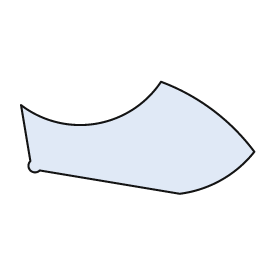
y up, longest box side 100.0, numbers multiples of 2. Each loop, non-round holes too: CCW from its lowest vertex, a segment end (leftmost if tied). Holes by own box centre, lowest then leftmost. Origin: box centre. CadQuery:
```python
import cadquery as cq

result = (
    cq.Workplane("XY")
    .moveTo(18.0, -24.0)
    .threePointArc((36.0, -18.0), (50.0, -6.0))
    .threePointArc((32.0, 12.0), (10.0, 24.0))
    .threePointArc((-18.0, 6.0), (-50.0, 14.0))
    .lineTo(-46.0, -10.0)
    .threePointArc((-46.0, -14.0), (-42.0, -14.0))
    .close()
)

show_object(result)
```